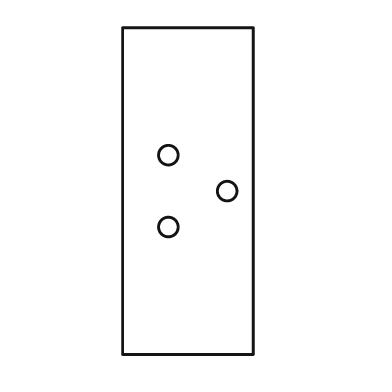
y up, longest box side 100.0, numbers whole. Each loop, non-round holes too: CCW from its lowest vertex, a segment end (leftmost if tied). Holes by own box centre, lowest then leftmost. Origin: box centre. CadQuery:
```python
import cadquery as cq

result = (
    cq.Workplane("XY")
    .moveTo(-20.0, -50.0)
    .lineTo(20.0, -50.0)
    .lineTo(20.0, 50.0)
    .lineTo(-20.0, 50.0)
    .close()
    .moveTo(-6.0, -11.0)
    .circle(3.0)
    .moveTo(12.0, 0.0)
    .circle(3.0)
    .moveTo(-6.0, 11.0)
    .circle(3.0)
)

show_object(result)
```